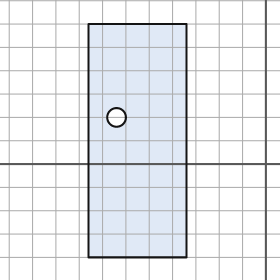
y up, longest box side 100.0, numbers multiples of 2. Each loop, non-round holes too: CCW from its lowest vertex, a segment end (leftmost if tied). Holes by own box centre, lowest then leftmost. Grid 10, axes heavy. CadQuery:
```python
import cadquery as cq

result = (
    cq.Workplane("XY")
    .moveTo(-76.0, -40.0)
    .lineTo(-34.0, -40.0)
    .lineTo(-34.0, 60.0)
    .lineTo(-76.0, 60.0)
    .close()
    .moveTo(-64.0, 20.0)
    .circle(4.0)
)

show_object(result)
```